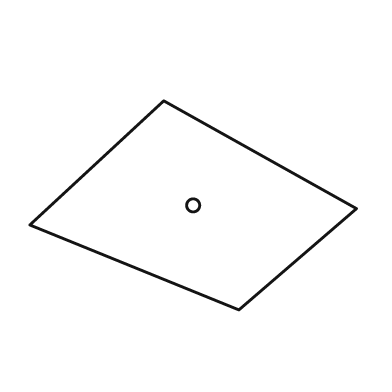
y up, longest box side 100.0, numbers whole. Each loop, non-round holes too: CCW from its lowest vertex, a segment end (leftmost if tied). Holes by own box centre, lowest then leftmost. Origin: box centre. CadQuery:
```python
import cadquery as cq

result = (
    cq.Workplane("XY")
    .moveTo(14.0, -32.0)
    .lineTo(50.0, -1.0)
    .lineTo(-9.0, 32.0)
    .lineTo(-50.0, -6.0)
    .close()
    .moveTo(0.0, 0.0)
    .circle(2.0)
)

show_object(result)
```